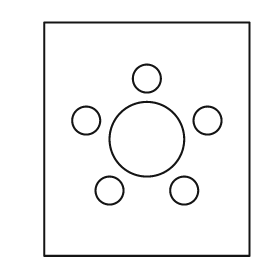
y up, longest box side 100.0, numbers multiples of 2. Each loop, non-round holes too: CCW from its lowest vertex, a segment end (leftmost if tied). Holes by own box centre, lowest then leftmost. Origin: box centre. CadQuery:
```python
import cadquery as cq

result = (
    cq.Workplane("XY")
    .moveTo(-44.0, -50.0)
    .lineTo(44.0, -50.0)
    .lineTo(44.0, 50.0)
    .lineTo(-44.0, 50.0)
    .close()
    .moveTo(-16.0, -22.0)
    .circle(6.0)
    .moveTo(16.0, -22.0)
    .circle(6.0)
    .moveTo(0.0, 0.0)
    .circle(16.0)
    .moveTo(-26.0, 8.0)
    .circle(6.0)
    .moveTo(26.0, 8.0)
    .circle(6.0)
    .moveTo(0.0, 26.0)
    .circle(6.0)
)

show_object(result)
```